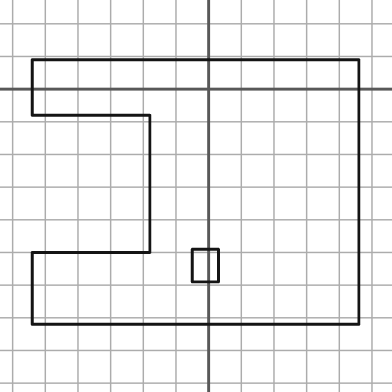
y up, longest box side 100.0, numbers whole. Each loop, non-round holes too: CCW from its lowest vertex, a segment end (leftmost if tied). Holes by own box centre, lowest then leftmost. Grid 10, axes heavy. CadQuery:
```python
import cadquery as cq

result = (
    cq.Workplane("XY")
    .moveTo(-54.0, -72.0)
    .lineTo(46.0, -72.0)
    .lineTo(46.0, 9.0)
    .lineTo(-54.0, 9.0)
    .lineTo(-54.0, -8.0)
    .lineTo(-18.0, -8.0)
    .lineTo(-18.0, -50.0)
    .lineTo(-54.0, -50.0)
    .close()
    .moveTo(-5.0, -59.0)
    .lineTo(3.0, -59.0)
    .lineTo(3.0, -49.0)
    .lineTo(-5.0, -49.0)
    .close()
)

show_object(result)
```